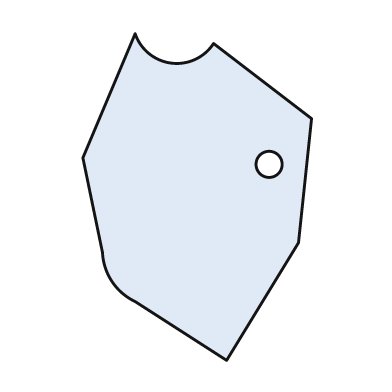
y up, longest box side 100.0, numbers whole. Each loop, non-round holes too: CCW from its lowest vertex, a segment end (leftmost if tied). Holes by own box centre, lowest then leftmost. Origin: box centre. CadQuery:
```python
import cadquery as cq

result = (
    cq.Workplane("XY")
    .moveTo(9.0, -50.0)
    .lineTo(31.0, -14.0)
    .lineTo(35.0, 24.0)
    .lineTo(5.0, 47.0)
    .threePointArc((-8.0, 41.0), (-19.0, 50.0))
    .lineTo(-35.0, 12.0)
    .lineTo(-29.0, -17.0)
    .threePointArc((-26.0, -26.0), (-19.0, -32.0))
    .close()
    .moveTo(22.0, 10.0)
    .circle(4.0)
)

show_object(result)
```